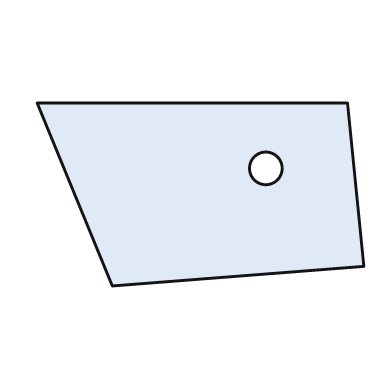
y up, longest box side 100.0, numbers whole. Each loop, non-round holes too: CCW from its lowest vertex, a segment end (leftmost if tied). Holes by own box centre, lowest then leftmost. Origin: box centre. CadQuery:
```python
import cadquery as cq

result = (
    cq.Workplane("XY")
    .moveTo(-27.0, -28.0)
    .lineTo(50.0, -22.0)
    .lineTo(45.0, 28.0)
    .lineTo(-50.0, 28.0)
    .close()
    .moveTo(20.0, 8.0)
    .circle(5.0)
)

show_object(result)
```